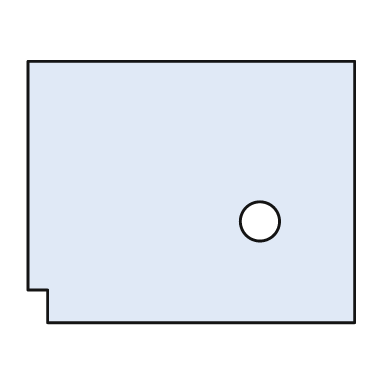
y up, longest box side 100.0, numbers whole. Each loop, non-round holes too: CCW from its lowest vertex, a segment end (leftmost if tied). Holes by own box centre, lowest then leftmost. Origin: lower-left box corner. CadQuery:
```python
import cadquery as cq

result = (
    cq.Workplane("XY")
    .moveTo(6.0, 0.0)
    .lineTo(100.0, 0.0)
    .lineTo(100.0, 80.0)
    .lineTo(0.0, 80.0)
    .lineTo(0.0, 10.0)
    .lineTo(6.0, 10.0)
    .close()
    .moveTo(71.0, 31.0)
    .circle(6.0)
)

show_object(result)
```